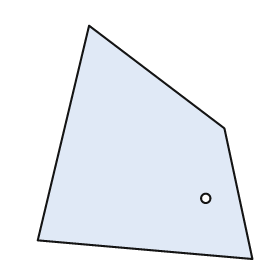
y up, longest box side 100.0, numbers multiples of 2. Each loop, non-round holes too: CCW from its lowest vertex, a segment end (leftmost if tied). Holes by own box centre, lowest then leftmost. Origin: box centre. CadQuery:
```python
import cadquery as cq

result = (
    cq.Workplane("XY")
    .moveTo(46.0, -50.0)
    .lineTo(34.0, 6.0)
    .lineTo(-24.0, 50.0)
    .lineTo(-46.0, -42.0)
    .close()
    .moveTo(26.0, -24.0)
    .circle(2.0)
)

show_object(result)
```